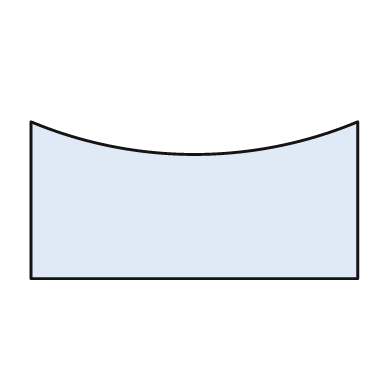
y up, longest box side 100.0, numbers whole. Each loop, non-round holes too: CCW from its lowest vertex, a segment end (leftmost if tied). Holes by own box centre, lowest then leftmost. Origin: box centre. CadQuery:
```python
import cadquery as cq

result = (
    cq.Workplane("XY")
    .moveTo(-50.0, -24.0)
    .lineTo(50.0, -24.0)
    .lineTo(50.0, 24.0)
    .threePointArc((0.0, 14.0), (-50.0, 24.0))
    .close()
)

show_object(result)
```